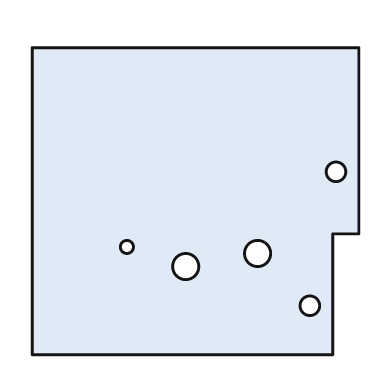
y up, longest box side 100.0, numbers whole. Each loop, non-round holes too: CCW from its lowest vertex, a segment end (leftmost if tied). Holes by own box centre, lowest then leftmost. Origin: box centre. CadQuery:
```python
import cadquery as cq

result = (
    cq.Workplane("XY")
    .moveTo(-50.0, -47.0)
    .lineTo(42.0, -47.0)
    .lineTo(42.0, -10.0)
    .lineTo(50.0, -10.0)
    .lineTo(50.0, 47.0)
    .lineTo(-50.0, 47.0)
    .close()
    .moveTo(35.0, -32.0)
    .circle(3.0)
    .moveTo(-3.0, -20.0)
    .circle(4.0)
    .moveTo(19.0, -16.0)
    .circle(4.0)
    .moveTo(-21.0, -14.0)
    .circle(2.0)
    .moveTo(43.0, 9.0)
    .circle(3.0)
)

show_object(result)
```